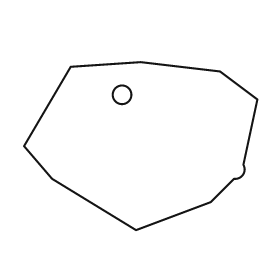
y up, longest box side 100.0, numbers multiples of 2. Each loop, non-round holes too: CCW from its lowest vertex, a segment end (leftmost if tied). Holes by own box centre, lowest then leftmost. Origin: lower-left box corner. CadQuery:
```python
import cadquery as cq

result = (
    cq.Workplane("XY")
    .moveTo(48.0, 0.0)
    .lineTo(80.0, 12.0)
    .lineTo(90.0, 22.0)
    .threePointArc((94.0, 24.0), (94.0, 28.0))
    .lineTo(100.0, 56.0)
    .lineTo(84.0, 68.0)
    .lineTo(50.0, 72.0)
    .lineTo(20.0, 70.0)
    .lineTo(0.0, 36.0)
    .lineTo(12.0, 22.0)
    .close()
    .moveTo(42.0, 58.0)
    .circle(4.0)
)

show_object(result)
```